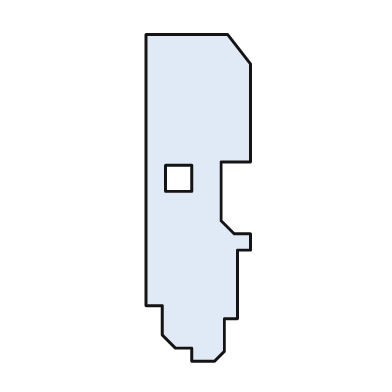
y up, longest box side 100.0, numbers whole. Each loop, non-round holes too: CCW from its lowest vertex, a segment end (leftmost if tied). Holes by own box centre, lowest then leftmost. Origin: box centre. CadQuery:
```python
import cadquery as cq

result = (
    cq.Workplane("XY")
    .moveTo(-2.0, -50.0)
    .lineTo(5.0, -50.0)
    .lineTo(8.0, -47.0)
    .lineTo(8.0, -37.0)
    .lineTo(12.0, -37.0)
    .lineTo(12.0, -16.0)
    .lineTo(16.0, -16.0)
    .lineTo(16.0, -11.0)
    .lineTo(11.0, -11.0)
    .lineTo(7.0, -7.0)
    .lineTo(7.0, 11.0)
    .lineTo(16.0, 11.0)
    .lineTo(16.0, 41.0)
    .lineTo(9.0, 50.0)
    .lineTo(-16.0, 50.0)
    .lineTo(-16.0, -33.0)
    .lineTo(-11.0, -33.0)
    .lineTo(-11.0, -42.0)
    .lineTo(-7.0, -46.0)
    .lineTo(-2.0, -46.0)
    .close()
    .moveTo(-10.0, 2.0)
    .lineTo(-2.0, 2.0)
    .lineTo(-2.0, 10.0)
    .lineTo(-10.0, 10.0)
    .close()
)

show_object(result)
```